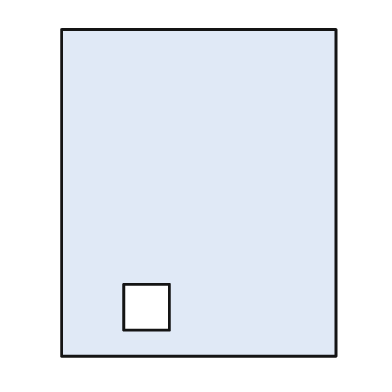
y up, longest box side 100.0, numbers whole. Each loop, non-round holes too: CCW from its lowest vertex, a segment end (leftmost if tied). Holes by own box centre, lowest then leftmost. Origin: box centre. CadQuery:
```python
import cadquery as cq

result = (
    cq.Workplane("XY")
    .moveTo(-42.0, -50.0)
    .lineTo(42.0, -50.0)
    .lineTo(42.0, 50.0)
    .lineTo(-42.0, 50.0)
    .close()
    .moveTo(-23.0, -42.0)
    .lineTo(-9.0, -42.0)
    .lineTo(-9.0, -28.0)
    .lineTo(-23.0, -28.0)
    .close()
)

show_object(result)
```